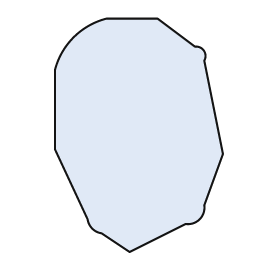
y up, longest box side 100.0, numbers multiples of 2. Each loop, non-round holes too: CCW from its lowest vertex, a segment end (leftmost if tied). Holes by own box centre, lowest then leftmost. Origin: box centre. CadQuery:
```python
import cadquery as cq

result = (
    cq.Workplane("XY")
    .moveTo(-4.0, -50.0)
    .lineTo(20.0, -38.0)
    .threePointArc((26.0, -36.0), (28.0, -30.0))
    .lineTo(36.0, -8.0)
    .lineTo(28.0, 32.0)
    .threePointArc((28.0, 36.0), (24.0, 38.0))
    .lineTo(8.0, 50.0)
    .lineTo(-14.0, 50.0)
    .threePointArc((-28.0, 42.0), (-36.0, 28.0))
    .lineTo(-36.0, -6.0)
    .lineTo(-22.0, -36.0)
    .threePointArc((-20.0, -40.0), (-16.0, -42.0))
    .close()
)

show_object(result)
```